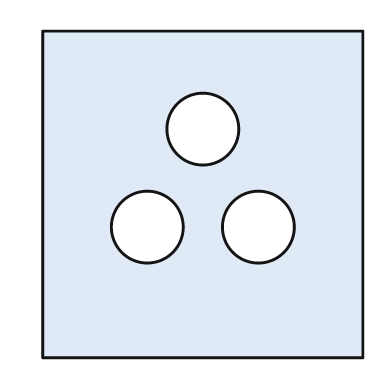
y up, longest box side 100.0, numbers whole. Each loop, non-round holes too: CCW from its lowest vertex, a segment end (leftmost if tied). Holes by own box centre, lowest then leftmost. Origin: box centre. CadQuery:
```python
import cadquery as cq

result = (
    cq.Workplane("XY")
    .moveTo(-49.0, -50.0)
    .lineTo(49.0, -50.0)
    .lineTo(49.0, 50.0)
    .lineTo(-49.0, 50.0)
    .close()
    .moveTo(-17.0, -10.0)
    .circle(11.0)
    .moveTo(17.0, -10.0)
    .circle(11.0)
    .moveTo(0.0, 20.0)
    .circle(11.0)
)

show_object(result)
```